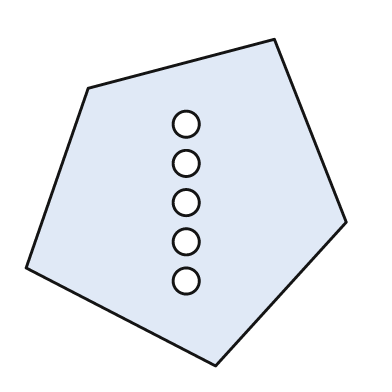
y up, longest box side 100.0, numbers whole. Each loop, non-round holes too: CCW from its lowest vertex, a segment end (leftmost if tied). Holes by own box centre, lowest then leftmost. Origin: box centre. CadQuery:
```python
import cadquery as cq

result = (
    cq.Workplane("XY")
    .moveTo(9.0, -50.0)
    .lineTo(49.0, -6.0)
    .lineTo(27.0, 50.0)
    .lineTo(-30.0, 35.0)
    .lineTo(-49.0, -20.0)
    .close()
    .moveTo(0.0, -24.0)
    .circle(4.0)
    .moveTo(0.0, -12.0)
    .circle(4.0)
    .moveTo(0.0, 0.0)
    .circle(4.0)
    .moveTo(0.0, 12.0)
    .circle(4.0)
    .moveTo(0.0, 24.0)
    .circle(4.0)
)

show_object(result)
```